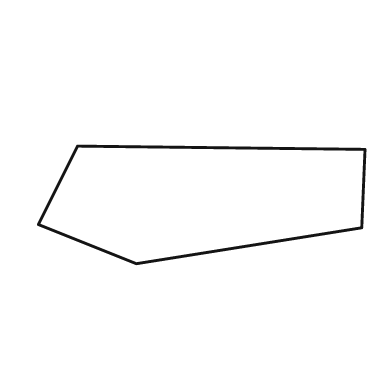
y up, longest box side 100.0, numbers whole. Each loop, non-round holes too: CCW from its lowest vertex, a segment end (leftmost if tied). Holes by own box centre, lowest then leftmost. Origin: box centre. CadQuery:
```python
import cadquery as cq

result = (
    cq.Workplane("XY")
    .moveTo(-20.0, -18.0)
    .lineTo(49.0, -7.0)
    .lineTo(50.0, 17.0)
    .lineTo(-38.0, 18.0)
    .lineTo(-50.0, -6.0)
    .close()
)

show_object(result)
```